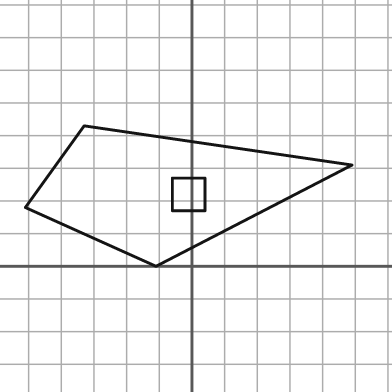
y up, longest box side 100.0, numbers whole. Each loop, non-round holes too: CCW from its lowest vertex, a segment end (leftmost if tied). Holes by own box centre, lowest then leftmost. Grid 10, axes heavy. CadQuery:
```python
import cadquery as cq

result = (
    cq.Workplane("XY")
    .moveTo(-11.0, 0.0)
    .lineTo(49.0, 31.0)
    .lineTo(-33.0, 43.0)
    .lineTo(-51.0, 18.0)
    .close()
    .moveTo(-6.0, 17.0)
    .lineTo(4.0, 17.0)
    .lineTo(4.0, 27.0)
    .lineTo(-6.0, 27.0)
    .close()
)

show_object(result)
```